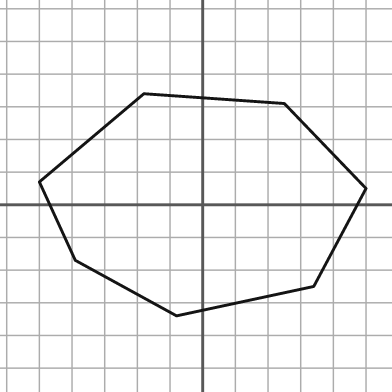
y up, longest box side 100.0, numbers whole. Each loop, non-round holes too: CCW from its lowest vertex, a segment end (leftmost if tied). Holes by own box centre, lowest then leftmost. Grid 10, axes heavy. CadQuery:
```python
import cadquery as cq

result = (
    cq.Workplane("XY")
    .moveTo(-8.0, -34.0)
    .lineTo(34.0, -25.0)
    .lineTo(50.0, 5.0)
    .lineTo(25.0, 31.0)
    .lineTo(-18.0, 34.0)
    .lineTo(-50.0, 7.0)
    .lineTo(-39.0, -17.0)
    .close()
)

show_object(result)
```